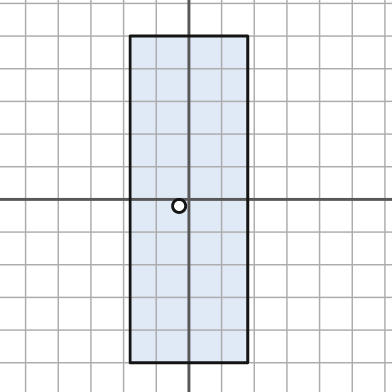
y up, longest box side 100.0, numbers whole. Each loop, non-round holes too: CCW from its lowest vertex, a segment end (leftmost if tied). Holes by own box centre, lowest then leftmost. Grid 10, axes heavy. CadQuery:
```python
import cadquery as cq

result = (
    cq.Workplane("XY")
    .moveTo(-18.0, -50.0)
    .lineTo(18.0, -50.0)
    .lineTo(18.0, 50.0)
    .lineTo(-18.0, 50.0)
    .close()
    .moveTo(-3.0, -2.0)
    .circle(2.0)
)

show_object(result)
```